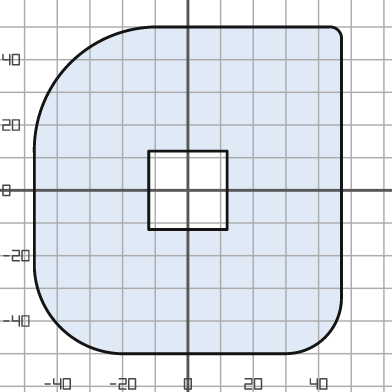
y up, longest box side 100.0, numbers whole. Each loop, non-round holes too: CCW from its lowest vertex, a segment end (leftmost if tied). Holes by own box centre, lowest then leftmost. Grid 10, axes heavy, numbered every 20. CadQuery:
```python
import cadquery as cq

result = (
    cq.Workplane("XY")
    .moveTo(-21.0, -50.0)
    .lineTo(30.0, -50.0)
    .threePointArc((42.0, -45.0), (47.0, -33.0))
    .lineTo(47.0, 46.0)
    .threePointArc((46.0, 49.0), (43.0, 50.0))
    .lineTo(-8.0, 50.0)
    .threePointArc((-36.0, 39.0), (-47.0, 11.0))
    .lineTo(-47.0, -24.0)
    .threePointArc((-39.0, -42.0), (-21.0, -50.0))
    .close()
    .moveTo(-12.0, -12.0)
    .lineTo(12.0, -12.0)
    .lineTo(12.0, 12.0)
    .lineTo(-12.0, 12.0)
    .close()
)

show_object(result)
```